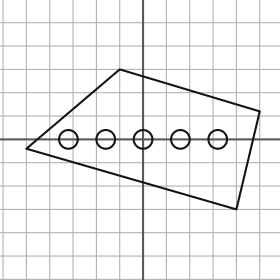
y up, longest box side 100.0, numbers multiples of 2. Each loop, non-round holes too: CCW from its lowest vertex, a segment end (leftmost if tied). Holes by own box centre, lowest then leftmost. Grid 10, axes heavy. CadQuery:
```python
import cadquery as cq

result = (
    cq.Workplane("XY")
    .moveTo(40.0, -30.0)
    .lineTo(50.0, 12.0)
    .lineTo(-10.0, 30.0)
    .lineTo(-50.0, -4.0)
    .close()
    .moveTo(-32.0, 0.0)
    .circle(4.0)
    .moveTo(-16.0, 0.0)
    .circle(4.0)
    .moveTo(0.0, 0.0)
    .circle(4.0)
    .moveTo(16.0, 0.0)
    .circle(4.0)
    .moveTo(32.0, 0.0)
    .circle(4.0)
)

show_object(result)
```